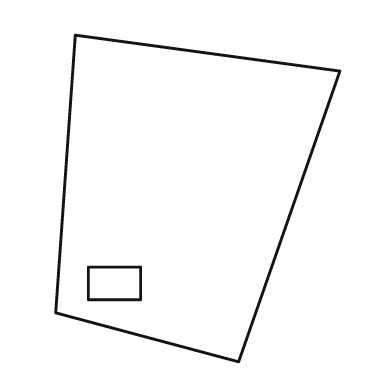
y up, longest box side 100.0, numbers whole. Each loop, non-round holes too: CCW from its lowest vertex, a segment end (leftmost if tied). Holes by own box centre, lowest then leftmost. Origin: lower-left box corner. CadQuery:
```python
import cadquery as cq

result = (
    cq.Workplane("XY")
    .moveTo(56.0, 0.0)
    .lineTo(87.0, 89.0)
    .lineTo(6.0, 100.0)
    .lineTo(0.0, 15.0)
    .close()
    .moveTo(10.0, 19.0)
    .lineTo(26.0, 19.0)
    .lineTo(26.0, 29.0)
    .lineTo(10.0, 29.0)
    .close()
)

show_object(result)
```